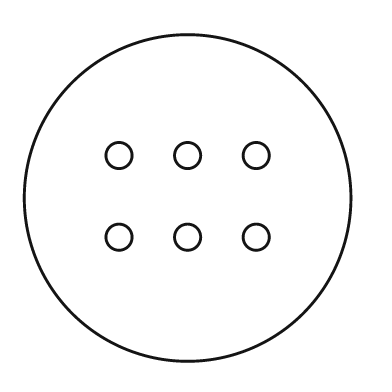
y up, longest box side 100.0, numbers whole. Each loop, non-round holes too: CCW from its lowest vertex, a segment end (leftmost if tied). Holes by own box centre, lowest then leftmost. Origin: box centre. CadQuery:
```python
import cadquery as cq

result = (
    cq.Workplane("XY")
    .moveTo(0.0, 0.0)
    .circle(50.0)
    .moveTo(-21.0, -12.0)
    .circle(4.0)
    .moveTo(0.0, -12.0)
    .circle(4.0)
    .moveTo(21.0, -12.0)
    .circle(4.0)
    .moveTo(-21.0, 13.0)
    .circle(4.0)
    .moveTo(0.0, 13.0)
    .circle(4.0)
    .moveTo(21.0, 13.0)
    .circle(4.0)
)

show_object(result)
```